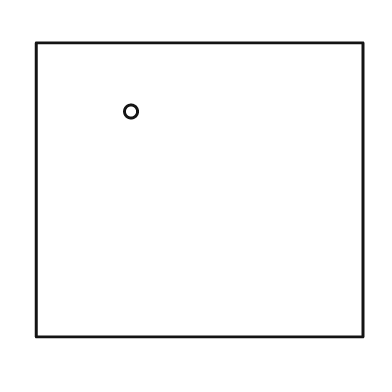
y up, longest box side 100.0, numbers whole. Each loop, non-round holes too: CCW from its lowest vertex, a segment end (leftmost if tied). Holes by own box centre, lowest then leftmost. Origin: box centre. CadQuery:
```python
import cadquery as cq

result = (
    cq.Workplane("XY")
    .moveTo(-50.0, -45.0)
    .lineTo(50.0, -45.0)
    .lineTo(50.0, 45.0)
    .lineTo(-50.0, 45.0)
    .close()
    .moveTo(-21.0, 24.0)
    .circle(2.0)
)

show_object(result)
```